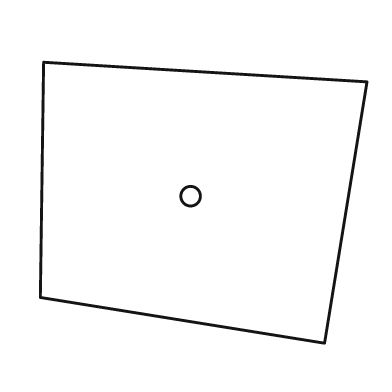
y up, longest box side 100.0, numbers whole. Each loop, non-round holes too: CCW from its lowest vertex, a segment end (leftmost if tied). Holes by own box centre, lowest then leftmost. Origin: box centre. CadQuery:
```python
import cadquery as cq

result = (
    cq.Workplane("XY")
    .moveTo(37.0, -43.0)
    .lineTo(50.0, 37.0)
    .lineTo(-49.0, 43.0)
    .lineTo(-50.0, -29.0)
    .close()
    .moveTo(-4.0, 2.0)
    .circle(3.0)
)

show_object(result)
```